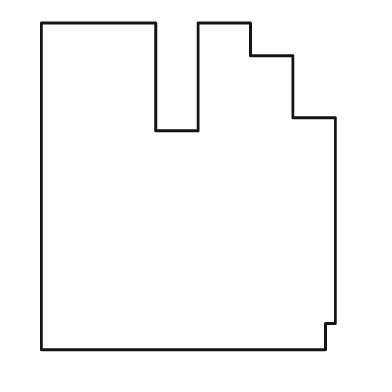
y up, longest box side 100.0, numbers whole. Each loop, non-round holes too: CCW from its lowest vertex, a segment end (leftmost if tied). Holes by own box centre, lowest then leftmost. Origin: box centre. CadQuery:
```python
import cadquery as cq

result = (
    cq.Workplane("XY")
    .moveTo(-45.0, -50.0)
    .lineTo(42.0, -50.0)
    .lineTo(42.0, -42.0)
    .lineTo(45.0, -42.0)
    .lineTo(45.0, 21.0)
    .lineTo(32.0, 21.0)
    .lineTo(32.0, 40.0)
    .lineTo(19.0, 40.0)
    .lineTo(19.0, 50.0)
    .lineTo(3.0, 50.0)
    .lineTo(3.0, 17.0)
    .lineTo(-10.0, 17.0)
    .lineTo(-10.0, 50.0)
    .lineTo(-45.0, 50.0)
    .close()
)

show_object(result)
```